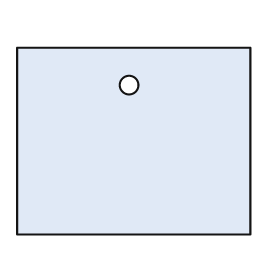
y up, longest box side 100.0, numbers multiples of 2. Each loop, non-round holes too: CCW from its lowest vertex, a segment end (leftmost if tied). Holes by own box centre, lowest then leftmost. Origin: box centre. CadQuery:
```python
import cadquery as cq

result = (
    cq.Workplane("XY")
    .moveTo(-50.0, -40.0)
    .lineTo(50.0, -40.0)
    .lineTo(50.0, 40.0)
    .lineTo(-50.0, 40.0)
    .close()
    .moveTo(-2.0, 24.0)
    .circle(4.0)
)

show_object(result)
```